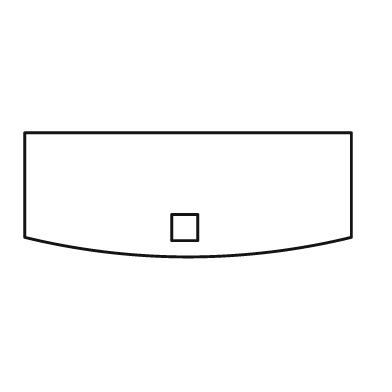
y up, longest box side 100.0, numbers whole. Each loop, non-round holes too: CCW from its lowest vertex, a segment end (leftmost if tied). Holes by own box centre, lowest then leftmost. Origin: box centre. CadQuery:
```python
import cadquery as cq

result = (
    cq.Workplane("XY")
    .moveTo(-50.0, -13.0)
    .threePointArc((0.0, -19.0), (50.0, -13.0))
    .lineTo(50.0, 19.0)
    .lineTo(-50.0, 19.0)
    .close()
    .moveTo(-5.0, -14.0)
    .lineTo(3.0, -14.0)
    .lineTo(3.0, -6.0)
    .lineTo(-5.0, -6.0)
    .close()
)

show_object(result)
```